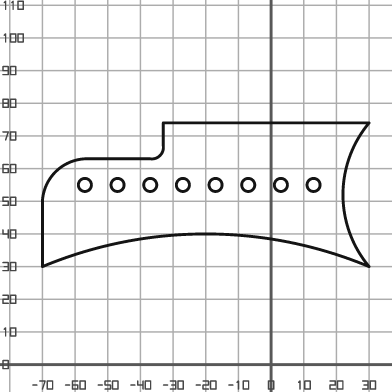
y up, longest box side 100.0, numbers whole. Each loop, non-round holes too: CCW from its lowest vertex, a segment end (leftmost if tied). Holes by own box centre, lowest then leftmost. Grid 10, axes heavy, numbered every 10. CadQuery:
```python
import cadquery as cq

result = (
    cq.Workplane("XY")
    .moveTo(-70.0, 30.0)
    .threePointArc((-20.0, 40.0), (30.0, 30.0))
    .threePointArc((22.0, 52.0), (30.0, 74.0))
    .lineTo(-33.0, 74.0)
    .lineTo(-33.0, 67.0)
    .threePointArc((-34.0, 64.0), (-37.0, 63.0))
    .lineTo(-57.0, 63.0)
    .threePointArc((-66.0, 59.0), (-70.0, 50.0))
    .close()
    .moveTo(-57.0, 55.0)
    .circle(2.0)
    .moveTo(-47.0, 55.0)
    .circle(2.0)
    .moveTo(-37.0, 55.0)
    .circle(2.0)
    .moveTo(-27.0, 55.0)
    .circle(2.0)
    .moveTo(-17.0, 55.0)
    .circle(2.0)
    .moveTo(-7.0, 55.0)
    .circle(2.0)
    .moveTo(3.0, 55.0)
    .circle(2.0)
    .moveTo(13.0, 55.0)
    .circle(2.0)
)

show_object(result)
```